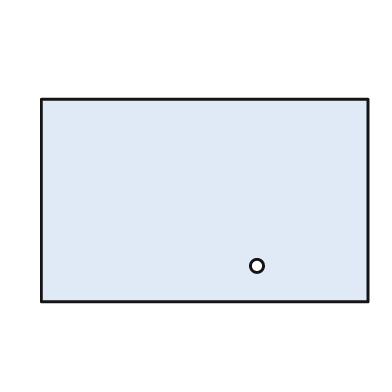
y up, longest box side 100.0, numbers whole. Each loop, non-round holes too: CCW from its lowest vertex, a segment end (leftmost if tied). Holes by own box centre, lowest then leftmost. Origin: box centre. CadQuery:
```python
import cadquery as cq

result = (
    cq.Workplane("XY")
    .moveTo(-50.0, -31.0)
    .lineTo(50.0, -31.0)
    .lineTo(50.0, 31.0)
    .lineTo(-50.0, 31.0)
    .close()
    .moveTo(16.0, -20.0)
    .circle(2.0)
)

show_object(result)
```